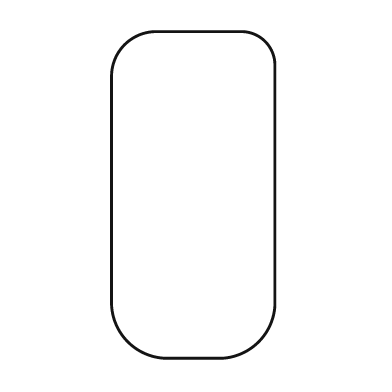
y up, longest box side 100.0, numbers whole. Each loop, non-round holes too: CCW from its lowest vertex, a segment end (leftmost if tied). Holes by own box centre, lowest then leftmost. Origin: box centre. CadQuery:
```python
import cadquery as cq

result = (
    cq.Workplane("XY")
    .moveTo(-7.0, -50.0)
    .lineTo(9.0, -50.0)
    .threePointArc((20.0, -45.0), (25.0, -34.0))
    .lineTo(25.0, 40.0)
    .threePointArc((22.0, 47.0), (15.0, 50.0))
    .lineTo(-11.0, 50.0)
    .threePointArc((-21.0, 46.0), (-25.0, 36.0))
    .lineTo(-25.0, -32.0)
    .threePointArc((-20.0, -45.0), (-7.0, -50.0))
    .close()
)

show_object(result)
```